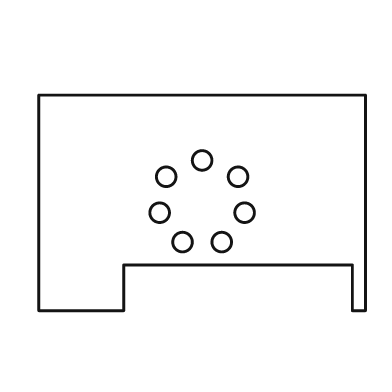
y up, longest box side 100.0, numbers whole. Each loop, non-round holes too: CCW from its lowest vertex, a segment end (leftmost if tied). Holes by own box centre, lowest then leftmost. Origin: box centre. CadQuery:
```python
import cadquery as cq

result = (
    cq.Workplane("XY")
    .moveTo(-50.0, -33.0)
    .lineTo(-24.0, -33.0)
    .lineTo(-24.0, -19.0)
    .lineTo(46.0, -19.0)
    .lineTo(46.0, -33.0)
    .lineTo(50.0, -33.0)
    .lineTo(50.0, 33.0)
    .lineTo(-50.0, 33.0)
    .close()
    .moveTo(-6.0, -12.0)
    .circle(3.0)
    .moveTo(6.0, -12.0)
    .circle(3.0)
    .moveTo(-13.0, -3.0)
    .circle(3.0)
    .moveTo(13.0, -3.0)
    .circle(3.0)
    .moveTo(-11.0, 8.0)
    .circle(3.0)
    .moveTo(11.0, 8.0)
    .circle(3.0)
    .moveTo(0.0, 13.0)
    .circle(3.0)
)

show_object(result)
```